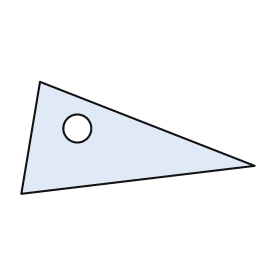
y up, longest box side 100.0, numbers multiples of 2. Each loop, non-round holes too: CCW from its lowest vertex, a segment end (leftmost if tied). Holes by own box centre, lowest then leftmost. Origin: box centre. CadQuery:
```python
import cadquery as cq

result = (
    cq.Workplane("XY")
    .moveTo(-50.0, -24.0)
    .lineTo(50.0, -12.0)
    .lineTo(-42.0, 24.0)
    .close()
    .moveTo(-26.0, 4.0)
    .circle(6.0)
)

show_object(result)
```